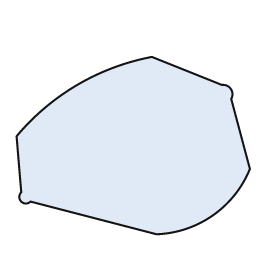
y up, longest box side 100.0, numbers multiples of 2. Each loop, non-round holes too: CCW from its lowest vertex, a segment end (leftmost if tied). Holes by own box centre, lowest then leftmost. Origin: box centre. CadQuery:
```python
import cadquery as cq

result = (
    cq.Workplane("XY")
    .moveTo(10.0, -38.0)
    .threePointArc((34.0, -30.0), (50.0, -10.0))
    .lineTo(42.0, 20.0)
    .threePointArc((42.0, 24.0), (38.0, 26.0))
    .lineTo(8.0, 38.0)
    .threePointArc((-24.0, 26.0), (-50.0, 4.0))
    .lineTo(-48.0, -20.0)
    .threePointArc((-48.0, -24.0), (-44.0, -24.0))
    .close()
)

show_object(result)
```